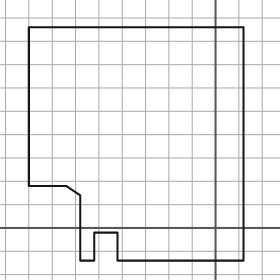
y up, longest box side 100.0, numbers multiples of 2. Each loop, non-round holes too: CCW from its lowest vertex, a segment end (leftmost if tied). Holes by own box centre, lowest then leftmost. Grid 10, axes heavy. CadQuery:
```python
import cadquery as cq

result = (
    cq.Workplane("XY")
    .moveTo(-58.0, -14.0)
    .lineTo(-52.0, -14.0)
    .lineTo(-52.0, -2.0)
    .lineTo(-42.0, -2.0)
    .lineTo(-42.0, -14.0)
    .lineTo(12.0, -14.0)
    .lineTo(12.0, 86.0)
    .lineTo(-80.0, 86.0)
    .lineTo(-80.0, 18.0)
    .lineTo(-64.0, 18.0)
    .lineTo(-58.0, 14.0)
    .close()
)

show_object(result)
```